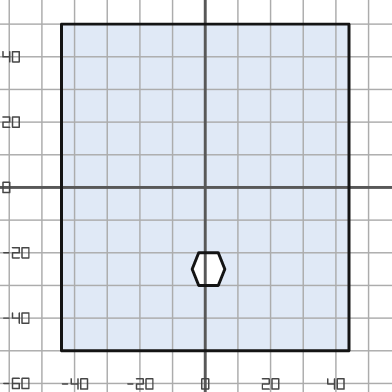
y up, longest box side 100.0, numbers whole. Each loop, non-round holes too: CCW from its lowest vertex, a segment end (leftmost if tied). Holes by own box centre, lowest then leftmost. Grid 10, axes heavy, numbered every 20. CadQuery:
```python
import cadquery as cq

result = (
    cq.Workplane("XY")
    .moveTo(-44.0, -50.0)
    .lineTo(44.0, -50.0)
    .lineTo(44.0, 50.0)
    .lineTo(-44.0, 50.0)
    .close()
    .moveTo(-2.0, -30.0)
    .lineTo(4.0, -30.0)
    .lineTo(6.0, -25.0)
    .lineTo(4.0, -20.0)
    .lineTo(-2.0, -20.0)
    .lineTo(-4.0, -25.0)
    .close()
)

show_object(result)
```